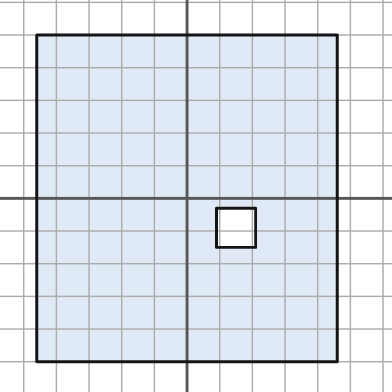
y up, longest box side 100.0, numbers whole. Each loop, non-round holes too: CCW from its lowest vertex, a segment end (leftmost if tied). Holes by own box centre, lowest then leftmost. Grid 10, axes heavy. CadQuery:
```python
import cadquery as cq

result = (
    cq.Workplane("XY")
    .moveTo(-46.0, -50.0)
    .lineTo(46.0, -50.0)
    .lineTo(46.0, 50.0)
    .lineTo(-46.0, 50.0)
    .close()
    .moveTo(9.0, -15.0)
    .lineTo(21.0, -15.0)
    .lineTo(21.0, -3.0)
    .lineTo(9.0, -3.0)
    .close()
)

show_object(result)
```